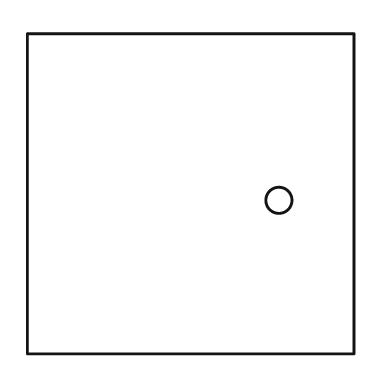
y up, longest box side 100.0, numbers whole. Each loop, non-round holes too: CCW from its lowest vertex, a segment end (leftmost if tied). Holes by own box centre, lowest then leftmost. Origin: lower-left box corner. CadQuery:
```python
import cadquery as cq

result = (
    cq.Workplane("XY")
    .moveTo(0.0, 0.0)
    .lineTo(100.0, 0.0)
    .lineTo(100.0, 98.0)
    .lineTo(0.0, 98.0)
    .close()
    .moveTo(77.0, 47.0)
    .circle(4.0)
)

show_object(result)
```